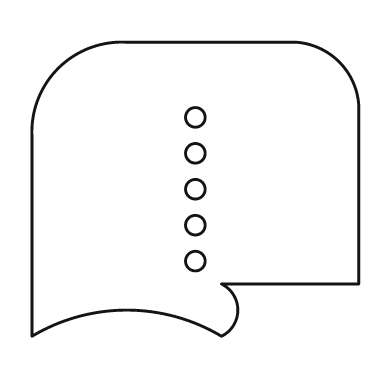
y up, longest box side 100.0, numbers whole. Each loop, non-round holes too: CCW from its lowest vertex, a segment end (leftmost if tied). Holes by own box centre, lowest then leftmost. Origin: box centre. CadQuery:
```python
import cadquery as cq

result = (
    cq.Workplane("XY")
    .moveTo(-50.0, -45.0)
    .threePointArc((-21.0, -37.0), (8.0, -45.0))
    .threePointArc((13.0, -37.0), (8.0, -29.0))
    .lineTo(50.0, -29.0)
    .lineTo(50.0, 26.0)
    .threePointArc((44.0, 39.0), (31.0, 45.0))
    .lineTo(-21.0, 45.0)
    .threePointArc((-42.0, 37.0), (-50.0, 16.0))
    .close()
    .moveTo(0.0, -22.0)
    .circle(3.0)
    .moveTo(0.0, -11.0)
    .circle(3.0)
    .moveTo(0.0, 0.0)
    .circle(3.0)
    .moveTo(0.0, 11.0)
    .circle(3.0)
    .moveTo(0.0, 22.0)
    .circle(3.0)
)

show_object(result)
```